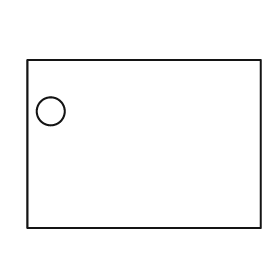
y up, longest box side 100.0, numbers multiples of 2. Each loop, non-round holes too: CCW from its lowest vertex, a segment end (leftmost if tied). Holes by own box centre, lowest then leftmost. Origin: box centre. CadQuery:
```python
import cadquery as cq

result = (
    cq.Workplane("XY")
    .moveTo(-50.0, -36.0)
    .lineTo(50.0, -36.0)
    .lineTo(50.0, 36.0)
    .lineTo(-50.0, 36.0)
    .close()
    .moveTo(-40.0, 14.0)
    .circle(6.0)
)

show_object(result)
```